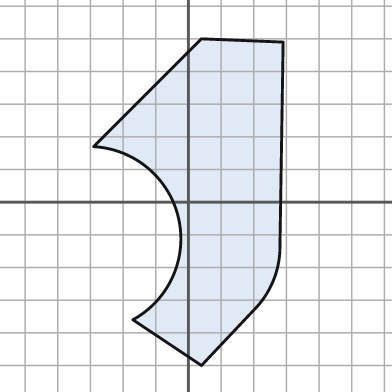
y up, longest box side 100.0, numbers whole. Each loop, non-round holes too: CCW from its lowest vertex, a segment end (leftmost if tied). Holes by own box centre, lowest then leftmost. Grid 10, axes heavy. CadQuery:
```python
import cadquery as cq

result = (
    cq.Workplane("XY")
    .moveTo(4.0, -50.0)
    .lineTo(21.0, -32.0)
    .threePointArc((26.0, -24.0), (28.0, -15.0))
    .lineTo(29.0, 49.0)
    .lineTo(4.0, 50.0)
    .lineTo(-29.0, 17.0)
    .threePointArc((-3.0, -5.0), (-17.0, -36.0))
    .close()
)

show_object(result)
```